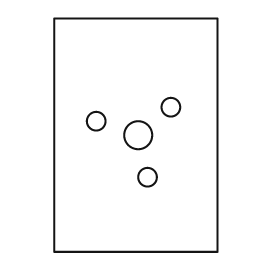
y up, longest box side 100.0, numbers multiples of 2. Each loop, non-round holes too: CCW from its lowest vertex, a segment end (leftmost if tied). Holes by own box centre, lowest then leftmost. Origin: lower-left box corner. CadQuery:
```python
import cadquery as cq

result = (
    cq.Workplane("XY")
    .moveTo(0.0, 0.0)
    .lineTo(70.0, 0.0)
    .lineTo(70.0, 100.0)
    .lineTo(0.0, 100.0)
    .close()
    .moveTo(40.0, 32.0)
    .circle(4.0)
    .moveTo(36.0, 50.0)
    .circle(6.0)
    .moveTo(18.0, 56.0)
    .circle(4.0)
    .moveTo(50.0, 62.0)
    .circle(4.0)
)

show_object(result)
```